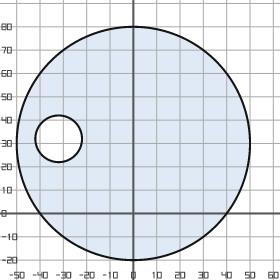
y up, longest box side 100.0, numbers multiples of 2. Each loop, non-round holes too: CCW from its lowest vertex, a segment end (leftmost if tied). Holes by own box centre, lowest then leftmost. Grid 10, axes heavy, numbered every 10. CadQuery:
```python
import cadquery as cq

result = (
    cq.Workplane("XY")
    .moveTo(0.0, 30.0)
    .circle(50.0)
    .moveTo(-32.0, 32.0)
    .circle(10.0)
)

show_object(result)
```